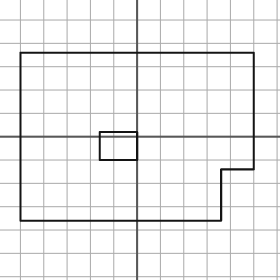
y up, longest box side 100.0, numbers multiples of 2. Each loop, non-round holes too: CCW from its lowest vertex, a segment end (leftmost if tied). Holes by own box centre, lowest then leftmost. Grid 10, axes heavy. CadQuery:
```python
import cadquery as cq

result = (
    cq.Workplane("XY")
    .moveTo(-50.0, -36.0)
    .lineTo(36.0, -36.0)
    .lineTo(36.0, -14.0)
    .lineTo(50.0, -14.0)
    .lineTo(50.0, 36.0)
    .lineTo(-50.0, 36.0)
    .close()
    .moveTo(-16.0, -10.0)
    .lineTo(0.0, -10.0)
    .lineTo(0.0, 2.0)
    .lineTo(-16.0, 2.0)
    .close()
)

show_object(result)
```